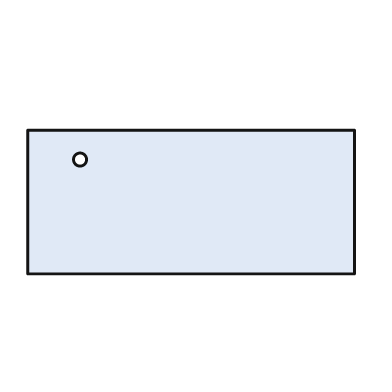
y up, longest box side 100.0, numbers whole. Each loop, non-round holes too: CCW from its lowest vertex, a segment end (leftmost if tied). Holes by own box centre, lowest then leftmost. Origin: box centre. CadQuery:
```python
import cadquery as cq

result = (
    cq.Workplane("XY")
    .moveTo(-50.0, -22.0)
    .lineTo(50.0, -22.0)
    .lineTo(50.0, 22.0)
    .lineTo(-50.0, 22.0)
    .close()
    .moveTo(-34.0, 13.0)
    .circle(2.0)
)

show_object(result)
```